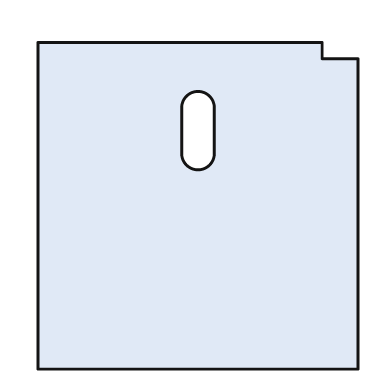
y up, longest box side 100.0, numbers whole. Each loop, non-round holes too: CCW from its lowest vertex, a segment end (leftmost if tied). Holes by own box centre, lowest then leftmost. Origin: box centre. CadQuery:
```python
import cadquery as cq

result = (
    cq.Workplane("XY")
    .moveTo(-49.0, -50.0)
    .lineTo(49.0, -50.0)
    .lineTo(49.0, 45.0)
    .lineTo(38.0, 45.0)
    .lineTo(38.0, 50.0)
    .lineTo(-49.0, 50.0)
    .close()
    .moveTo(-5.0, 16.0)
    .threePointArc((0.0, 11.0), (5.0, 16.0))
    .lineTo(5.0, 30.0)
    .threePointArc((0.0, 35.0), (-5.0, 30.0))
    .close()
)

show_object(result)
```